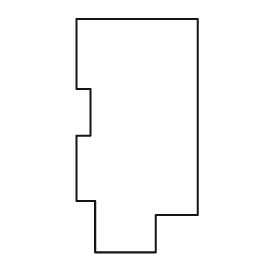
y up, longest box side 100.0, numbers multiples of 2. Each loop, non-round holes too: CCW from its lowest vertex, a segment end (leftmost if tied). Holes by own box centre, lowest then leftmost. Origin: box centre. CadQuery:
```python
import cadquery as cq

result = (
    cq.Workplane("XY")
    .moveTo(-18.0, -50.0)
    .lineTo(8.0, -50.0)
    .lineTo(8.0, -34.0)
    .lineTo(26.0, -34.0)
    .lineTo(26.0, 50.0)
    .lineTo(-26.0, 50.0)
    .lineTo(-26.0, 20.0)
    .lineTo(-20.0, 20.0)
    .lineTo(-20.0, 0.0)
    .lineTo(-26.0, 0.0)
    .lineTo(-26.0, -28.0)
    .lineTo(-18.0, -28.0)
    .close()
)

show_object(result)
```